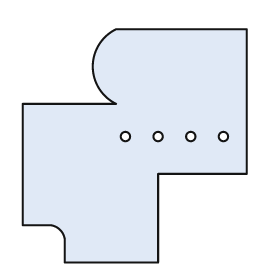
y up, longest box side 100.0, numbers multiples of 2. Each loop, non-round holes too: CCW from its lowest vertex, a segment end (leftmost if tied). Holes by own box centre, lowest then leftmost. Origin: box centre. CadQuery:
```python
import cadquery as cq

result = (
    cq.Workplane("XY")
    .moveTo(-30.0, -50.0)
    .lineTo(10.0, -50.0)
    .lineTo(10.0, -12.0)
    .lineTo(48.0, -12.0)
    .lineTo(48.0, 50.0)
    .lineTo(-8.0, 50.0)
    .threePointArc((-18.0, 34.0), (-8.0, 18.0))
    .lineTo(-48.0, 18.0)
    .lineTo(-48.0, -34.0)
    .lineTo(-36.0, -34.0)
    .threePointArc((-32.0, -36.0), (-30.0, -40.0))
    .close()
    .moveTo(-4.0, 4.0)
    .circle(2.0)
    .moveTo(10.0, 4.0)
    .circle(2.0)
    .moveTo(24.0, 4.0)
    .circle(2.0)
    .moveTo(38.0, 4.0)
    .circle(2.0)
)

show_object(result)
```